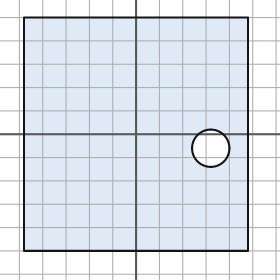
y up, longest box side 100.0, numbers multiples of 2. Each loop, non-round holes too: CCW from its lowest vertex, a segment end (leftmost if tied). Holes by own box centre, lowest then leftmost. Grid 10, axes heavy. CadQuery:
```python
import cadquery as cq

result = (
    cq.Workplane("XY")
    .moveTo(-48.0, -50.0)
    .lineTo(48.0, -50.0)
    .lineTo(48.0, 50.0)
    .lineTo(-48.0, 50.0)
    .close()
    .moveTo(32.0, -6.0)
    .circle(8.0)
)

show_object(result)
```